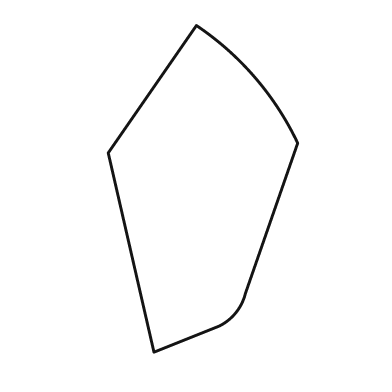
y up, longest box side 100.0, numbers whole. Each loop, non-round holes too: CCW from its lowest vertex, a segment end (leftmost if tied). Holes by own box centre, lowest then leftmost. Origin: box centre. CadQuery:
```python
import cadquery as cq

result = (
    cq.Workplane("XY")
    .moveTo(-15.0, -50.0)
    .lineTo(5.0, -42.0)
    .threePointArc((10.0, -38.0), (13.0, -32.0))
    .lineTo(29.0, 14.0)
    .threePointArc((16.0, 34.0), (-2.0, 50.0))
    .lineTo(-29.0, 11.0)
    .close()
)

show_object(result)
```